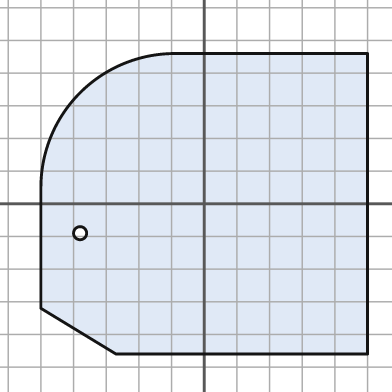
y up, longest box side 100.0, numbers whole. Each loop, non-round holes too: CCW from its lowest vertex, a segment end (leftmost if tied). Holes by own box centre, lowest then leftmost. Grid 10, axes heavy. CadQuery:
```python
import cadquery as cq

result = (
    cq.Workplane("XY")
    .moveTo(-27.0, -46.0)
    .lineTo(50.0, -46.0)
    .lineTo(50.0, 46.0)
    .lineTo(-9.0, 46.0)
    .threePointArc((-38.0, 34.0), (-50.0, 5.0))
    .lineTo(-50.0, -32.0)
    .close()
    .moveTo(-38.0, -9.0)
    .circle(2.0)
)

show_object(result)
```